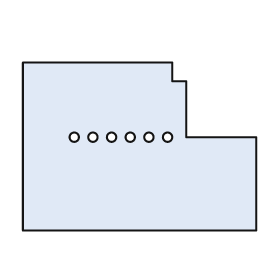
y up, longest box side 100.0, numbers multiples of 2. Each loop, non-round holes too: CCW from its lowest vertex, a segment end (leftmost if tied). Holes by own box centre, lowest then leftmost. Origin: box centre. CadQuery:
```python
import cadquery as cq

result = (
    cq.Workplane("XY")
    .moveTo(-50.0, -36.0)
    .lineTo(50.0, -36.0)
    .lineTo(50.0, 4.0)
    .lineTo(20.0, 4.0)
    .lineTo(20.0, 28.0)
    .lineTo(14.0, 28.0)
    .lineTo(14.0, 36.0)
    .lineTo(-50.0, 36.0)
    .close()
    .moveTo(-28.0, 4.0)
    .circle(2.0)
    .moveTo(-20.0, 4.0)
    .circle(2.0)
    .moveTo(-12.0, 4.0)
    .circle(2.0)
    .moveTo(-4.0, 4.0)
    .circle(2.0)
    .moveTo(4.0, 4.0)
    .circle(2.0)
    .moveTo(12.0, 4.0)
    .circle(2.0)
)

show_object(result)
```